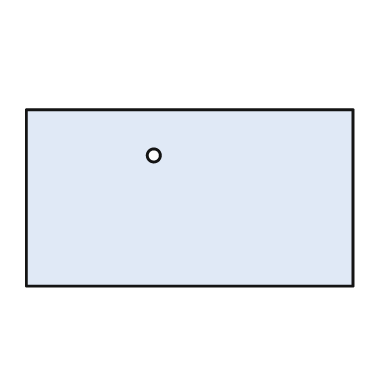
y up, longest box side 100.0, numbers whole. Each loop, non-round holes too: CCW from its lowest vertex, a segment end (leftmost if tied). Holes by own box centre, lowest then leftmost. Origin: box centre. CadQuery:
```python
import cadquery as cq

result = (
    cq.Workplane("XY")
    .moveTo(-50.0, -27.0)
    .lineTo(50.0, -27.0)
    .lineTo(50.0, 27.0)
    .lineTo(-50.0, 27.0)
    .close()
    .moveTo(-11.0, 13.0)
    .circle(2.0)
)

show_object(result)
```